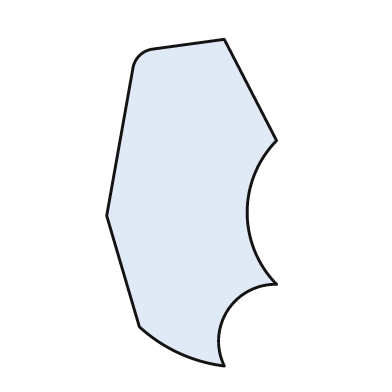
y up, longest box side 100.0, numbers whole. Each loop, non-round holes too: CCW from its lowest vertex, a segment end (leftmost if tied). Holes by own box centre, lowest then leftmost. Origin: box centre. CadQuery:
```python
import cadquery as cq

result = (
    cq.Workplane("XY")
    .moveTo(10.0, -50.0)
    .threePointArc((11.0, -33.0), (26.0, -25.0))
    .threePointArc((17.0, -3.0), (26.0, 19.0))
    .lineTo(10.0, 50.0)
    .lineTo(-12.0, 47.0)
    .threePointArc((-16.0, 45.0), (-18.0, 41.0))
    .lineTo(-26.0, -4.0)
    .lineTo(-16.0, -38.0)
    .threePointArc((-4.0, -46.0), (10.0, -50.0))
    .close()
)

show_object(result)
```